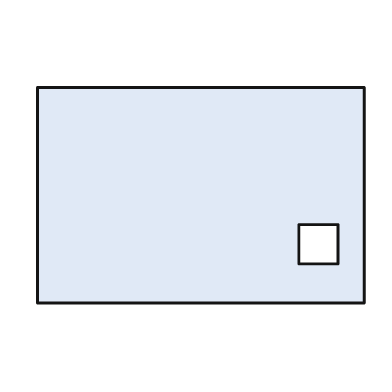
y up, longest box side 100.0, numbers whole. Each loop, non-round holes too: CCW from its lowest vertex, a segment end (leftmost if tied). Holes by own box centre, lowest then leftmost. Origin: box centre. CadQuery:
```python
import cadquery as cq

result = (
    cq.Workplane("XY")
    .moveTo(-50.0, -33.0)
    .lineTo(50.0, -33.0)
    .lineTo(50.0, 33.0)
    .lineTo(-50.0, 33.0)
    .close()
    .moveTo(30.0, -21.0)
    .lineTo(42.0, -21.0)
    .lineTo(42.0, -9.0)
    .lineTo(30.0, -9.0)
    .close()
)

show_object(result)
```